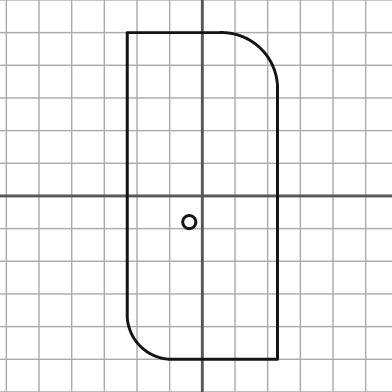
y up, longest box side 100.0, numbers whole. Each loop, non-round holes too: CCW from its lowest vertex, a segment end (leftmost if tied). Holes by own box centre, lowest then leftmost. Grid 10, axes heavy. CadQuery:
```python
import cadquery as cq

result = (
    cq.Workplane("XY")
    .moveTo(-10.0, -50.0)
    .lineTo(23.0, -50.0)
    .lineTo(23.0, 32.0)
    .threePointArc((18.0, 45.0), (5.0, 50.0))
    .lineTo(-23.0, 50.0)
    .lineTo(-23.0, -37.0)
    .threePointArc((-19.0, -46.0), (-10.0, -50.0))
    .close()
    .moveTo(-4.0, -8.0)
    .circle(2.0)
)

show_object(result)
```